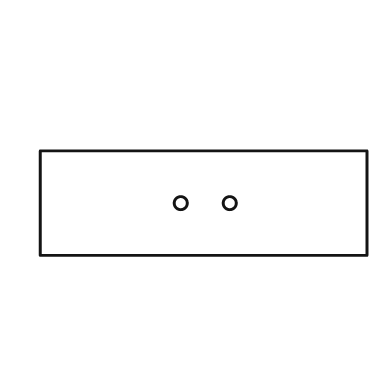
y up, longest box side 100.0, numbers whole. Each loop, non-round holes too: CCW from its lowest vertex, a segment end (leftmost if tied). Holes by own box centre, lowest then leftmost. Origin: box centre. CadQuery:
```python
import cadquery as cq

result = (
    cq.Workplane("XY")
    .moveTo(-50.0, -16.0)
    .lineTo(50.0, -16.0)
    .lineTo(50.0, 16.0)
    .lineTo(-50.0, 16.0)
    .close()
    .moveTo(-7.0, 0.0)
    .circle(2.0)
    .moveTo(8.0, 0.0)
    .circle(2.0)
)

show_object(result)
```